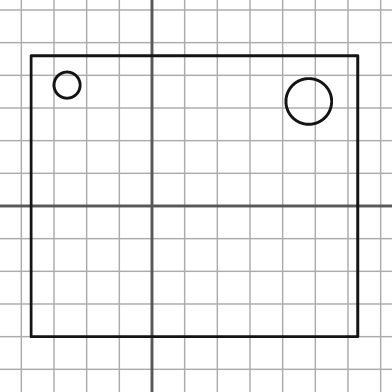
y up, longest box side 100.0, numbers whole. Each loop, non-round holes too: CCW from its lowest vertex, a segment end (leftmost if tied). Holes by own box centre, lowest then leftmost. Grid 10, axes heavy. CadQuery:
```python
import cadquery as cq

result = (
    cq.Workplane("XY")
    .moveTo(-37.0, -40.0)
    .lineTo(63.0, -40.0)
    .lineTo(63.0, 46.0)
    .lineTo(-37.0, 46.0)
    .close()
    .moveTo(48.0, 32.0)
    .circle(7.0)
    .moveTo(-26.0, 37.0)
    .circle(4.0)
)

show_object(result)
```